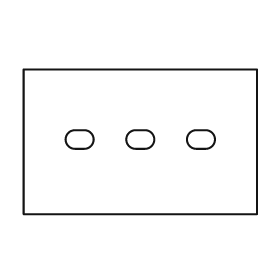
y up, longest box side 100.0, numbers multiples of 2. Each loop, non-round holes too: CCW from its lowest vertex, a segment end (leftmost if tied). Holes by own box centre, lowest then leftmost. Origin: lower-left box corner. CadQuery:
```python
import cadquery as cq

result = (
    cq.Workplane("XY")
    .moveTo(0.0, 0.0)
    .lineTo(100.0, 0.0)
    .lineTo(100.0, 62.0)
    .lineTo(0.0, 62.0)
    .close()
    .moveTo(22.0, 28.0)
    .lineTo(26.0, 28.0)
    .threePointArc((30.0, 32.0), (26.0, 36.0))
    .lineTo(22.0, 36.0)
    .threePointArc((18.0, 32.0), (22.0, 28.0))
    .close()
    .moveTo(48.0, 28.0)
    .lineTo(52.0, 28.0)
    .threePointArc((56.0, 32.0), (52.0, 36.0))
    .lineTo(48.0, 36.0)
    .threePointArc((44.0, 32.0), (48.0, 28.0))
    .close()
    .moveTo(74.0, 28.0)
    .lineTo(78.0, 28.0)
    .threePointArc((82.0, 32.0), (78.0, 36.0))
    .lineTo(74.0, 36.0)
    .threePointArc((70.0, 32.0), (74.0, 28.0))
    .close()
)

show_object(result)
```